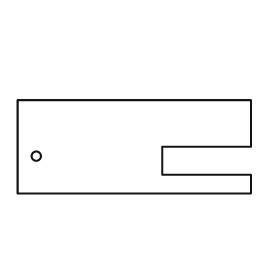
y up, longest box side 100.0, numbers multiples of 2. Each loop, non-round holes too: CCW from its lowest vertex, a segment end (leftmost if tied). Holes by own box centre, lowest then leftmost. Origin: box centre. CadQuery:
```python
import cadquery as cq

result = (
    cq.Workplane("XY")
    .moveTo(-50.0, -20.0)
    .lineTo(50.0, -20.0)
    .lineTo(50.0, -12.0)
    .lineTo(12.0, -12.0)
    .lineTo(12.0, 0.0)
    .lineTo(50.0, 0.0)
    .lineTo(50.0, 20.0)
    .lineTo(-50.0, 20.0)
    .close()
    .moveTo(-42.0, -4.0)
    .circle(2.0)
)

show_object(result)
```